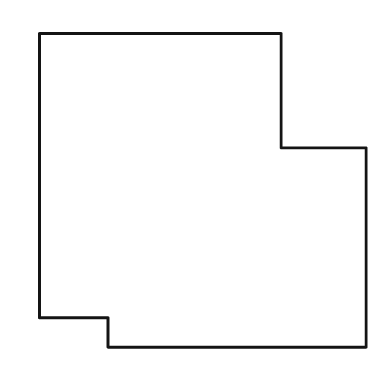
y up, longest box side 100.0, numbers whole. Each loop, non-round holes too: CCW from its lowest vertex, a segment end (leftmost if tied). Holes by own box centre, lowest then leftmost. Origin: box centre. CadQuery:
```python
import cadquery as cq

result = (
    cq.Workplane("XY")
    .moveTo(-29.0, -48.0)
    .lineTo(50.0, -48.0)
    .lineTo(50.0, 13.0)
    .lineTo(24.0, 13.0)
    .lineTo(24.0, 48.0)
    .lineTo(-50.0, 48.0)
    .lineTo(-50.0, -39.0)
    .lineTo(-29.0, -39.0)
    .close()
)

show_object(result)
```